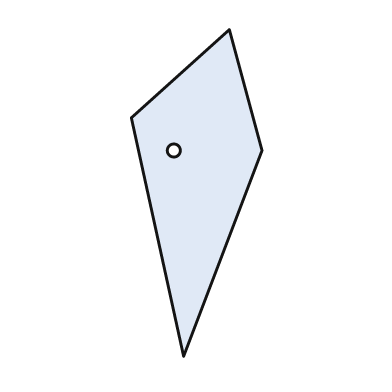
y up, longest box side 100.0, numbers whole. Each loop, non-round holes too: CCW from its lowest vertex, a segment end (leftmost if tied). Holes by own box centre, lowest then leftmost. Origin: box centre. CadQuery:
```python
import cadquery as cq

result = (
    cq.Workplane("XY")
    .moveTo(-4.0, -50.0)
    .lineTo(20.0, 13.0)
    .lineTo(10.0, 50.0)
    .lineTo(-20.0, 23.0)
    .close()
    .moveTo(-7.0, 13.0)
    .circle(2.0)
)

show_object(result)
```